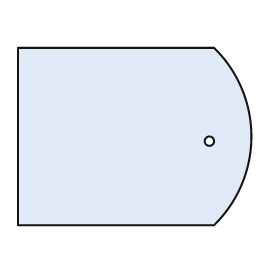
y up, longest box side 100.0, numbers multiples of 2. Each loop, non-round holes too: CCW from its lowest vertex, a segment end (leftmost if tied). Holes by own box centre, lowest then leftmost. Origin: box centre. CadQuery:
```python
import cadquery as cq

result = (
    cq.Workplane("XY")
    .moveTo(-50.0, -38.0)
    .lineTo(34.0, -38.0)
    .threePointArc((50.0, 0.0), (34.0, 38.0))
    .lineTo(-50.0, 38.0)
    .close()
    .moveTo(32.0, -2.0)
    .circle(2.0)
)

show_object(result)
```